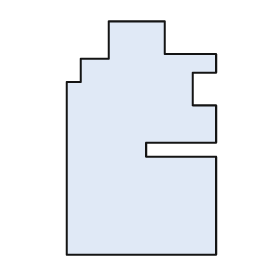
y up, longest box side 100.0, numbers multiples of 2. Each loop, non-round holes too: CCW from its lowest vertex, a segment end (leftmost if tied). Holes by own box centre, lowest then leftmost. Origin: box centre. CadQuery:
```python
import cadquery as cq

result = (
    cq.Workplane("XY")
    .moveTo(-32.0, -50.0)
    .lineTo(32.0, -50.0)
    .lineTo(32.0, -8.0)
    .lineTo(2.0, -8.0)
    .lineTo(2.0, -2.0)
    .lineTo(32.0, -2.0)
    .lineTo(32.0, 14.0)
    .lineTo(22.0, 14.0)
    .lineTo(22.0, 28.0)
    .lineTo(32.0, 28.0)
    .lineTo(32.0, 36.0)
    .lineTo(10.0, 36.0)
    .lineTo(10.0, 50.0)
    .lineTo(-14.0, 50.0)
    .lineTo(-14.0, 34.0)
    .lineTo(-26.0, 34.0)
    .lineTo(-26.0, 24.0)
    .lineTo(-32.0, 24.0)
    .close()
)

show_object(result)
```